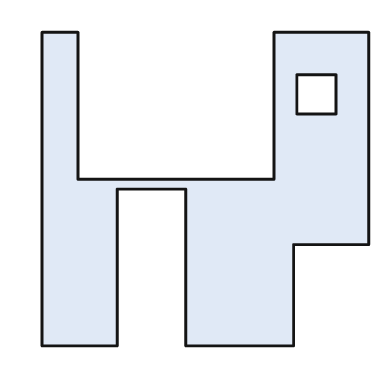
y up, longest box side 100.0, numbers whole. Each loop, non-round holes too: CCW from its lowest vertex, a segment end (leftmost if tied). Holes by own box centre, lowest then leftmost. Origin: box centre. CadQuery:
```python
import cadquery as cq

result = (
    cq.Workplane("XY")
    .moveTo(-50.0, -48.0)
    .lineTo(-27.0, -48.0)
    .lineTo(-27.0, 0.0)
    .lineTo(-6.0, 0.0)
    .lineTo(-6.0, -48.0)
    .lineTo(27.0, -48.0)
    .lineTo(27.0, -17.0)
    .lineTo(50.0, -17.0)
    .lineTo(50.0, 48.0)
    .lineTo(21.0, 48.0)
    .lineTo(21.0, 3.0)
    .lineTo(-39.0, 3.0)
    .lineTo(-39.0, 48.0)
    .lineTo(-50.0, 48.0)
    .close()
    .moveTo(28.0, 23.0)
    .lineTo(40.0, 23.0)
    .lineTo(40.0, 35.0)
    .lineTo(28.0, 35.0)
    .close()
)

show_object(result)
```